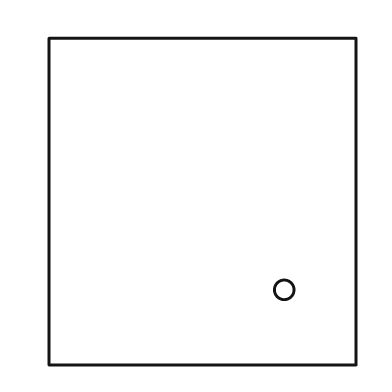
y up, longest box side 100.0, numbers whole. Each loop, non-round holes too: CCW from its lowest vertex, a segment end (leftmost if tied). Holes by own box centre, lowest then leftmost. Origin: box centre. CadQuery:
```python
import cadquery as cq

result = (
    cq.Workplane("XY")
    .moveTo(-47.0, -50.0)
    .lineTo(47.0, -50.0)
    .lineTo(47.0, 50.0)
    .lineTo(-47.0, 50.0)
    .close()
    .moveTo(25.0, -27.0)
    .circle(3.0)
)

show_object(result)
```